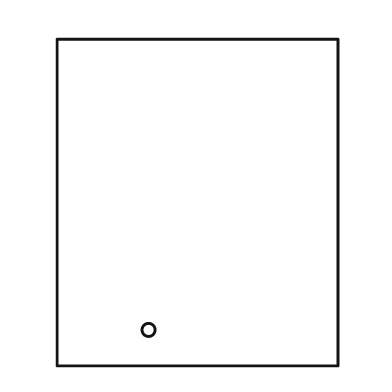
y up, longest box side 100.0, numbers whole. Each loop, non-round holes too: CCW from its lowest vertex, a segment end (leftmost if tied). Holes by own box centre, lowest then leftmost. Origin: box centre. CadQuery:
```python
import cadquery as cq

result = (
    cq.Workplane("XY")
    .moveTo(-43.0, -50.0)
    .lineTo(43.0, -50.0)
    .lineTo(43.0, 50.0)
    .lineTo(-43.0, 50.0)
    .close()
    .moveTo(-15.0, -39.0)
    .circle(2.0)
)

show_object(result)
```